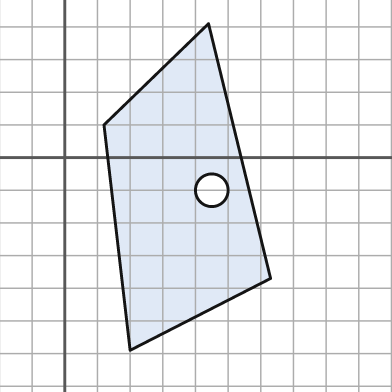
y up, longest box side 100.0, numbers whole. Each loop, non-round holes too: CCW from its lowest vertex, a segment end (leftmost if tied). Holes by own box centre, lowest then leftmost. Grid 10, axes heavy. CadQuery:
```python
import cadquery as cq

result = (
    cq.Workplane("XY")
    .moveTo(20.0, -59.0)
    .lineTo(63.0, -37.0)
    .lineTo(44.0, 41.0)
    .lineTo(12.0, 10.0)
    .close()
    .moveTo(45.0, -10.0)
    .circle(5.0)
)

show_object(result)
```